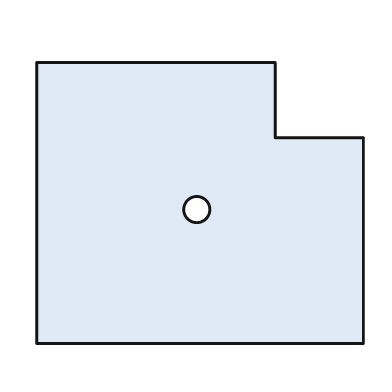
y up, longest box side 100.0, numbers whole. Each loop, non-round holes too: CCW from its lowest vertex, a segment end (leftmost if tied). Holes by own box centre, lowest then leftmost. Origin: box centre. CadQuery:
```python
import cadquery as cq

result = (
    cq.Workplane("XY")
    .moveTo(-50.0, -43.0)
    .lineTo(50.0, -43.0)
    .lineTo(50.0, 20.0)
    .lineTo(23.0, 20.0)
    .lineTo(23.0, 43.0)
    .lineTo(-50.0, 43.0)
    .close()
    .moveTo(-1.0, -2.0)
    .circle(4.0)
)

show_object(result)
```